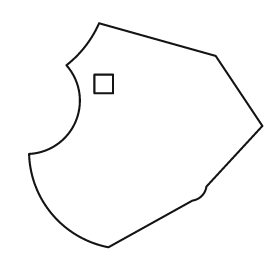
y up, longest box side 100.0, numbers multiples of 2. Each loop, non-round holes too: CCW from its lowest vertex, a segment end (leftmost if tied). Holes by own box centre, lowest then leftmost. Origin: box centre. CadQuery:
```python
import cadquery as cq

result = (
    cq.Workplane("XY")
    .moveTo(-16.0, -48.0)
    .lineTo(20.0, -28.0)
    .threePointArc((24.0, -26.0), (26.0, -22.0))
    .lineTo(50.0, 4.0)
    .lineTo(30.0, 34.0)
    .lineTo(-20.0, 48.0)
    .threePointArc((-26.0, 38.0), (-34.0, 30.0))
    .threePointArc((-30.0, 6.0), (-50.0, -8.0))
    .threePointArc((-40.0, -34.0), (-16.0, -48.0))
    .close()
    .moveTo(-22.0, 18.0)
    .lineTo(-14.0, 18.0)
    .lineTo(-14.0, 26.0)
    .lineTo(-22.0, 26.0)
    .close()
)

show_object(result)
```